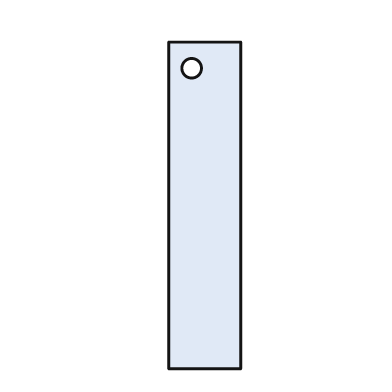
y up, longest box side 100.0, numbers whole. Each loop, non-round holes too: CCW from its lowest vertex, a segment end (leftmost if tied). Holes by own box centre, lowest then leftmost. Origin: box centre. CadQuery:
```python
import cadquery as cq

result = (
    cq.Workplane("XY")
    .moveTo(-11.0, -50.0)
    .lineTo(11.0, -50.0)
    .lineTo(11.0, 50.0)
    .lineTo(-11.0, 50.0)
    .close()
    .moveTo(-4.0, 42.0)
    .circle(3.0)
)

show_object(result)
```